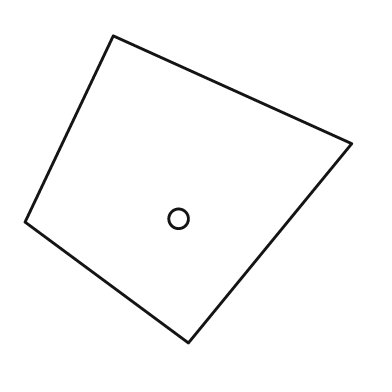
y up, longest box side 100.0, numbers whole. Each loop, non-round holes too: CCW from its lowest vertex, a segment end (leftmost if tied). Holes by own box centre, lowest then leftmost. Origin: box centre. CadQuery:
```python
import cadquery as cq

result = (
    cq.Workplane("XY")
    .moveTo(0.0, -47.0)
    .lineTo(50.0, 14.0)
    .lineTo(-23.0, 47.0)
    .lineTo(-50.0, -10.0)
    .close()
    .moveTo(-3.0, -9.0)
    .circle(3.0)
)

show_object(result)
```